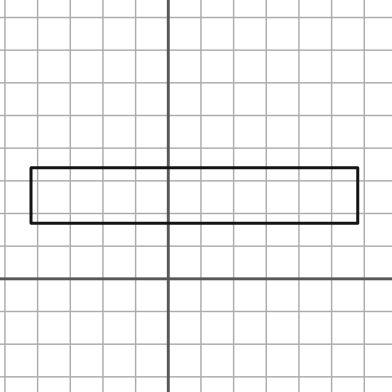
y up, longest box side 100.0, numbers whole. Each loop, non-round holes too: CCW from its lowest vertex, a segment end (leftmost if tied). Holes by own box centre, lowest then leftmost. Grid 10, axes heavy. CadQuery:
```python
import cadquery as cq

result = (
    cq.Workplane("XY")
    .moveTo(-42.0, 17.0)
    .lineTo(58.0, 17.0)
    .lineTo(58.0, 34.0)
    .lineTo(-42.0, 34.0)
    .close()
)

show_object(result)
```